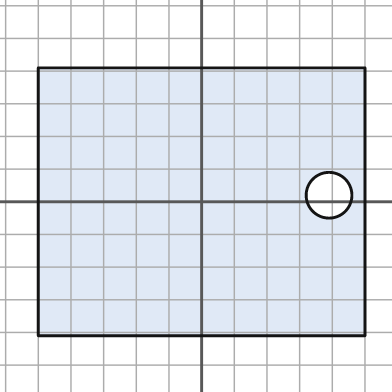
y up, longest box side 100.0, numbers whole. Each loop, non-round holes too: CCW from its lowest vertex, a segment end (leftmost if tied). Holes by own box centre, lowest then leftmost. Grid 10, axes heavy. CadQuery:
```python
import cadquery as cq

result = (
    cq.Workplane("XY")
    .moveTo(-50.0, -41.0)
    .lineTo(50.0, -41.0)
    .lineTo(50.0, 41.0)
    .lineTo(-50.0, 41.0)
    .close()
    .moveTo(39.0, 2.0)
    .circle(7.0)
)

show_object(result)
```